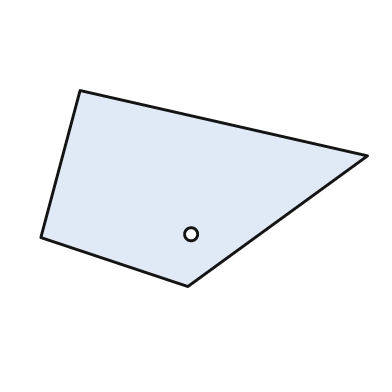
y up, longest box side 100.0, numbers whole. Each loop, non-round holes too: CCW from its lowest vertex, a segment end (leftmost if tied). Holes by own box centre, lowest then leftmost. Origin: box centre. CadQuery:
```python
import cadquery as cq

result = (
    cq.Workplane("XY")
    .moveTo(-5.0, -30.0)
    .lineTo(50.0, 10.0)
    .lineTo(-38.0, 30.0)
    .lineTo(-50.0, -15.0)
    .close()
    .moveTo(-4.0, -14.0)
    .circle(2.0)
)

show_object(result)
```